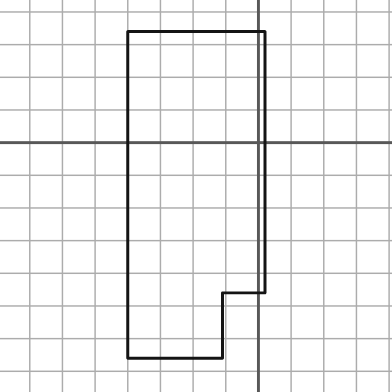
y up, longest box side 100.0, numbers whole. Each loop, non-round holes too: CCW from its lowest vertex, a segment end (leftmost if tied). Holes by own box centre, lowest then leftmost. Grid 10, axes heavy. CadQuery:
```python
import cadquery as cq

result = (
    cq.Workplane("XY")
    .moveTo(-40.0, -66.0)
    .lineTo(-11.0, -66.0)
    .lineTo(-11.0, -46.0)
    .lineTo(2.0, -46.0)
    .lineTo(2.0, 34.0)
    .lineTo(-40.0, 34.0)
    .close()
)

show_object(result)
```